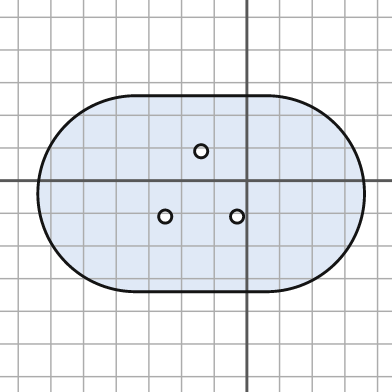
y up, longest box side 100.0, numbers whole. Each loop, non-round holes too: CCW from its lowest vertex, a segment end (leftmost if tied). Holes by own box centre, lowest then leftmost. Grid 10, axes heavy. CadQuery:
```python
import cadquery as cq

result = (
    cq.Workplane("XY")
    .moveTo(-34.0, -34.0)
    .lineTo(6.0, -34.0)
    .threePointArc((36.0, -4.0), (6.0, 26.0))
    .lineTo(-34.0, 26.0)
    .threePointArc((-64.0, -4.0), (-34.0, -34.0))
    .close()
    .moveTo(-25.0, -11.0)
    .circle(2.0)
    .moveTo(-3.0, -11.0)
    .circle(2.0)
    .moveTo(-14.0, 9.0)
    .circle(2.0)
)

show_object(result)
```